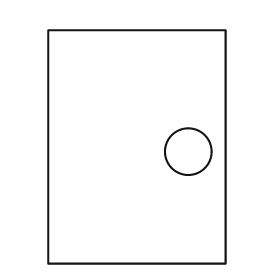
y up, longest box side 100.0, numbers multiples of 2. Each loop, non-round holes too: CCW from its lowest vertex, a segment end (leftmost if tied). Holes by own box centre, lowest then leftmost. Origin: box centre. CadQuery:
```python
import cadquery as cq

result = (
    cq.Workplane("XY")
    .moveTo(-38.0, -50.0)
    .lineTo(38.0, -50.0)
    .lineTo(38.0, 50.0)
    .lineTo(-38.0, 50.0)
    .close()
    .moveTo(22.0, -2.0)
    .circle(10.0)
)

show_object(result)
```